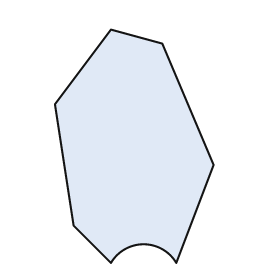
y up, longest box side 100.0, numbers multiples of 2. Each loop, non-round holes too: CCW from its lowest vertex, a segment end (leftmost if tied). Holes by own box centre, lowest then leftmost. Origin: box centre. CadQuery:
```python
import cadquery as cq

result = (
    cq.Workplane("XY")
    .moveTo(-10.0, -50.0)
    .threePointArc((4.0, -42.0), (18.0, -50.0))
    .lineTo(34.0, -8.0)
    .lineTo(12.0, 44.0)
    .lineTo(-10.0, 50.0)
    .lineTo(-34.0, 18.0)
    .lineTo(-26.0, -34.0)
    .close()
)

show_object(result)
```